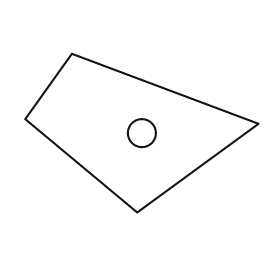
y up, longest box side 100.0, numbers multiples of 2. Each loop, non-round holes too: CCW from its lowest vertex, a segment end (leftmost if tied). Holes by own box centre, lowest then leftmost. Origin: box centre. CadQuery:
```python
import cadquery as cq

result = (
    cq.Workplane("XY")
    .moveTo(-2.0, -34.0)
    .lineTo(50.0, 4.0)
    .lineTo(-30.0, 34.0)
    .lineTo(-50.0, 6.0)
    .close()
    .moveTo(0.0, 0.0)
    .circle(6.0)
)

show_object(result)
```